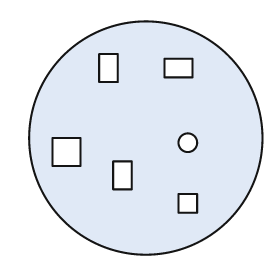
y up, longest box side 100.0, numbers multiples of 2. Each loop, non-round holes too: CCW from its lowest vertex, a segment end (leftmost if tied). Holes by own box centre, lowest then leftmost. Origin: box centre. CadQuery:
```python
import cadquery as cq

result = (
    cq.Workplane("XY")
    .moveTo(0.0, 0.0)
    .circle(50.0)
    .moveTo(14.0, -32.0)
    .lineTo(22.0, -32.0)
    .lineTo(22.0, -24.0)
    .lineTo(14.0, -24.0)
    .close()
    .moveTo(-14.0, -22.0)
    .lineTo(-6.0, -22.0)
    .lineTo(-6.0, -10.0)
    .lineTo(-14.0, -10.0)
    .close()
    .moveTo(-40.0, -12.0)
    .lineTo(-28.0, -12.0)
    .lineTo(-28.0, 0.0)
    .lineTo(-40.0, 0.0)
    .close()
    .moveTo(18.0, -2.0)
    .circle(4.0)
    .moveTo(-20.0, 24.0)
    .lineTo(-12.0, 24.0)
    .lineTo(-12.0, 36.0)
    .lineTo(-20.0, 36.0)
    .close()
    .moveTo(8.0, 26.0)
    .lineTo(20.0, 26.0)
    .lineTo(20.0, 34.0)
    .lineTo(8.0, 34.0)
    .close()
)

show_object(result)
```